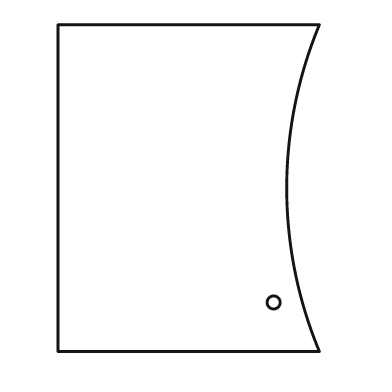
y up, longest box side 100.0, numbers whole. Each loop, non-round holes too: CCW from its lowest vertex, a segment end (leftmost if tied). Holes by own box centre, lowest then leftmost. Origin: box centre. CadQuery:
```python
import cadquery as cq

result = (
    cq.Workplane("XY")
    .moveTo(-40.0, -50.0)
    .lineTo(40.0, -50.0)
    .threePointArc((30.0, 0.0), (40.0, 50.0))
    .lineTo(-40.0, 50.0)
    .close()
    .moveTo(26.0, -35.0)
    .circle(2.0)
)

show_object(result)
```